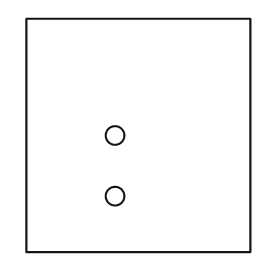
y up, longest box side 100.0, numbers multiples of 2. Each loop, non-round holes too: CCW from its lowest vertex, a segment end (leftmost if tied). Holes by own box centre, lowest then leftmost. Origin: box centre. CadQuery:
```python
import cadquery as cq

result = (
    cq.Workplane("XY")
    .moveTo(-48.0, -50.0)
    .lineTo(48.0, -50.0)
    .lineTo(48.0, 50.0)
    .lineTo(-48.0, 50.0)
    .close()
    .moveTo(-10.0, -26.0)
    .circle(4.0)
    .moveTo(-10.0, 0.0)
    .circle(4.0)
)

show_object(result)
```